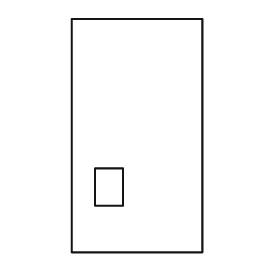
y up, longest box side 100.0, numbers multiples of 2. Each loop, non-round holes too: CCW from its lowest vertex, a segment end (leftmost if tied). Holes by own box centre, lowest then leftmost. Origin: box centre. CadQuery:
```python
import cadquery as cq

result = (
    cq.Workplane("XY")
    .moveTo(-28.0, -50.0)
    .lineTo(28.0, -50.0)
    .lineTo(28.0, 50.0)
    .lineTo(-28.0, 50.0)
    .close()
    .moveTo(-18.0, -30.0)
    .lineTo(-6.0, -30.0)
    .lineTo(-6.0, -14.0)
    .lineTo(-18.0, -14.0)
    .close()
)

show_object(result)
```